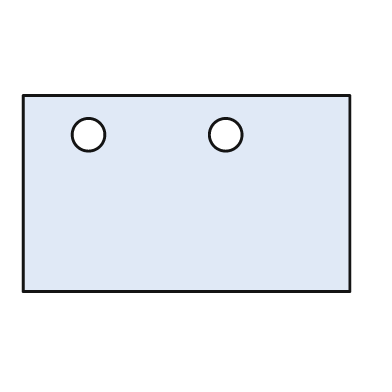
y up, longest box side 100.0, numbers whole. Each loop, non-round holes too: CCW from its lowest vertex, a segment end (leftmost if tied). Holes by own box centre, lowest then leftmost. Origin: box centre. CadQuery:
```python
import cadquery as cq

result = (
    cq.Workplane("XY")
    .moveTo(-50.0, -30.0)
    .lineTo(50.0, -30.0)
    .lineTo(50.0, 30.0)
    .lineTo(-50.0, 30.0)
    .close()
    .moveTo(-30.0, 18.0)
    .circle(5.0)
    .moveTo(12.0, 18.0)
    .circle(5.0)
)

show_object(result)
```